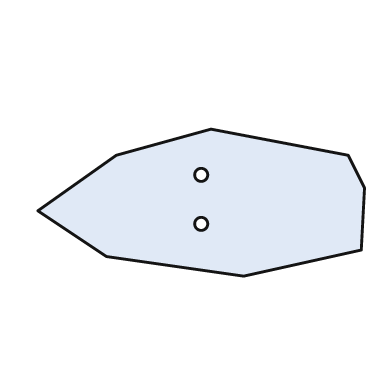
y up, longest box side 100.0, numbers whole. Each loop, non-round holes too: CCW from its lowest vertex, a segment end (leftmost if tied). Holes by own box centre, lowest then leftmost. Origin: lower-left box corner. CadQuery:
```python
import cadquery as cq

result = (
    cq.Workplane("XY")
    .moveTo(63.0, 0.0)
    .lineTo(99.0, 8.0)
    .lineTo(100.0, 27.0)
    .lineTo(95.0, 37.0)
    .lineTo(53.0, 45.0)
    .lineTo(24.0, 37.0)
    .lineTo(0.0, 20.0)
    .lineTo(21.0, 6.0)
    .close()
    .moveTo(50.0, 16.0)
    .circle(2.0)
    .moveTo(50.0, 31.0)
    .circle(2.0)
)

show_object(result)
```